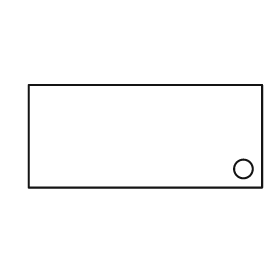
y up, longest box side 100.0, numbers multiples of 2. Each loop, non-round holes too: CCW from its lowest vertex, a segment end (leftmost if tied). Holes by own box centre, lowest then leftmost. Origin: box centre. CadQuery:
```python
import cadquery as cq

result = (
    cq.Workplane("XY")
    .moveTo(-50.0, -22.0)
    .lineTo(50.0, -22.0)
    .lineTo(50.0, 22.0)
    .lineTo(-50.0, 22.0)
    .close()
    .moveTo(42.0, -14.0)
    .circle(4.0)
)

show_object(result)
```